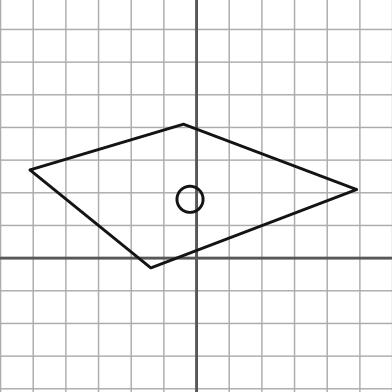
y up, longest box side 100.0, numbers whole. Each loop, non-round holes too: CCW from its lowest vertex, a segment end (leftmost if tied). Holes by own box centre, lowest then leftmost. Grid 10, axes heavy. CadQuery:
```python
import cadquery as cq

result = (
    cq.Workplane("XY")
    .moveTo(-14.0, -3.0)
    .lineTo(49.0, 21.0)
    .lineTo(-4.0, 41.0)
    .lineTo(-51.0, 27.0)
    .close()
    .moveTo(-2.0, 18.0)
    .circle(4.0)
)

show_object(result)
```